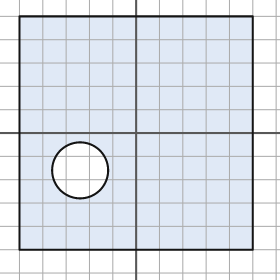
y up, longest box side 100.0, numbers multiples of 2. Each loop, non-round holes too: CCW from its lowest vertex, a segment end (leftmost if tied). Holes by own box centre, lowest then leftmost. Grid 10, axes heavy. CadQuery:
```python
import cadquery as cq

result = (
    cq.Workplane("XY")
    .moveTo(-50.0, -50.0)
    .lineTo(50.0, -50.0)
    .lineTo(50.0, 50.0)
    .lineTo(-50.0, 50.0)
    .close()
    .moveTo(-24.0, -16.0)
    .circle(12.0)
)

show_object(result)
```